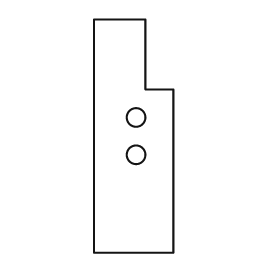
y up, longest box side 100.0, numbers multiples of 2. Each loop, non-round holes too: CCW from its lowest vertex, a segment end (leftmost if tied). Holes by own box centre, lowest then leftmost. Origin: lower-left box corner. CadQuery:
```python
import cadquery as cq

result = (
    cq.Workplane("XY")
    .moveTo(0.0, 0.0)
    .lineTo(34.0, 0.0)
    .lineTo(34.0, 70.0)
    .lineTo(22.0, 70.0)
    .lineTo(22.0, 100.0)
    .lineTo(0.0, 100.0)
    .close()
    .moveTo(18.0, 42.0)
    .circle(4.0)
    .moveTo(18.0, 58.0)
    .circle(4.0)
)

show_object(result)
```